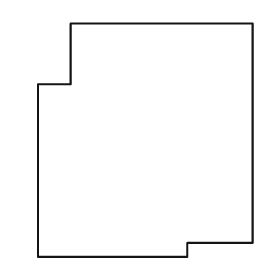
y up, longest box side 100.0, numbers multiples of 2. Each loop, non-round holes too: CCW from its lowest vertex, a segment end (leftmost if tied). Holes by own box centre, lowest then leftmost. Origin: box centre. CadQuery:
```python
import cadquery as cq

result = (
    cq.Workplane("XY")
    .moveTo(-46.0, -50.0)
    .lineTo(18.0, -50.0)
    .lineTo(18.0, -44.0)
    .lineTo(46.0, -44.0)
    .lineTo(46.0, 50.0)
    .lineTo(-32.0, 50.0)
    .lineTo(-32.0, 24.0)
    .lineTo(-46.0, 24.0)
    .close()
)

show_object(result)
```